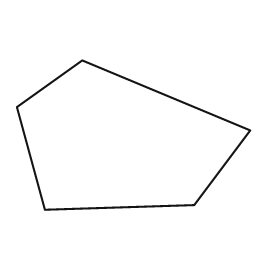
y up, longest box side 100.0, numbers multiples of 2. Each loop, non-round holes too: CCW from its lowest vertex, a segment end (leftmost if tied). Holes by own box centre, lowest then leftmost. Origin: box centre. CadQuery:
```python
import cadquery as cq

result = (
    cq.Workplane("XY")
    .moveTo(-38.0, -32.0)
    .lineTo(26.0, -30.0)
    .lineTo(50.0, 2.0)
    .lineTo(-22.0, 32.0)
    .lineTo(-50.0, 12.0)
    .close()
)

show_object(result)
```